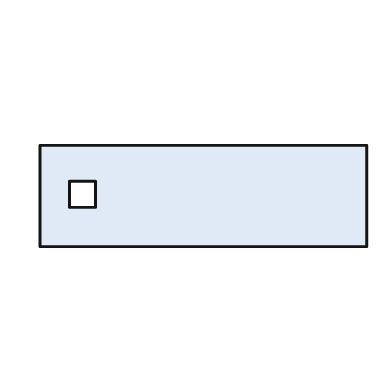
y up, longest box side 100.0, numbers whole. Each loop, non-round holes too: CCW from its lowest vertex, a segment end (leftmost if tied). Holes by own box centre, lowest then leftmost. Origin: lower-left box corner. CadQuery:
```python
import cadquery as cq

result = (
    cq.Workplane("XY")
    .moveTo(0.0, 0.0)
    .lineTo(100.0, 0.0)
    .lineTo(100.0, 31.0)
    .lineTo(0.0, 31.0)
    .close()
    .moveTo(9.0, 12.0)
    .lineTo(17.0, 12.0)
    .lineTo(17.0, 20.0)
    .lineTo(9.0, 20.0)
    .close()
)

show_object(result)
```